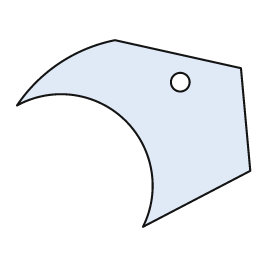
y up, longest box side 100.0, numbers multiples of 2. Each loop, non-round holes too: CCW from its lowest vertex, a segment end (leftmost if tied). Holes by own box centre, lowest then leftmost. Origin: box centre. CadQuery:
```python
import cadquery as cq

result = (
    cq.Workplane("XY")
    .moveTo(4.0, -40.0)
    .lineTo(50.0, -16.0)
    .lineTo(46.0, 28.0)
    .lineTo(-8.0, 40.0)
    .threePointArc((-32.0, 30.0), (-50.0, 12.0))
    .threePointArc((-4.0, 6.0), (4.0, -40.0))
    .close()
    .moveTo(20.0, 22.0)
    .circle(4.0)
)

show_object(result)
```